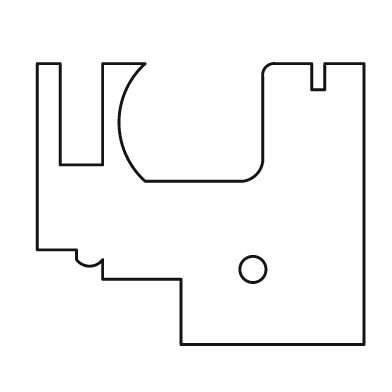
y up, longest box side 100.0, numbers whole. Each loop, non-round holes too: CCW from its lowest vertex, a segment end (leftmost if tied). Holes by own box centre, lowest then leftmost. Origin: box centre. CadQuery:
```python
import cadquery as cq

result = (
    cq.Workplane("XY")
    .moveTo(-6.0, -43.0)
    .lineTo(50.0, -43.0)
    .lineTo(50.0, 43.0)
    .lineTo(38.0, 43.0)
    .lineTo(38.0, 35.0)
    .lineTo(34.0, 35.0)
    .lineTo(34.0, 43.0)
    .lineTo(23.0, 43.0)
    .threePointArc((20.0, 42.0), (19.0, 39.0))
    .lineTo(19.0, 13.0)
    .threePointArc((17.0, 9.0), (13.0, 7.0))
    .lineTo(-17.0, 7.0)
    .threePointArc((-25.0, 25.0), (-17.0, 43.0))
    .lineTo(-30.0, 43.0)
    .lineTo(-30.0, 12.0)
    .lineTo(-43.0, 12.0)
    .lineTo(-43.0, 43.0)
    .lineTo(-50.0, 43.0)
    .lineTo(-50.0, -14.0)
    .lineTo(-38.0, -14.0)
    .lineTo(-38.0, -17.0)
    .threePointArc((-34.0, -19.0), (-30.0, -17.0))
    .lineTo(-30.0, -23.0)
    .lineTo(-6.0, -23.0)
    .close()
    .moveTo(16.0, -20.0)
    .circle(4.0)
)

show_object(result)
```